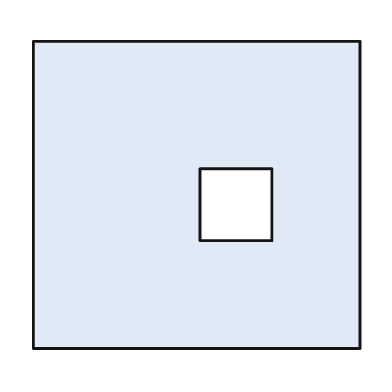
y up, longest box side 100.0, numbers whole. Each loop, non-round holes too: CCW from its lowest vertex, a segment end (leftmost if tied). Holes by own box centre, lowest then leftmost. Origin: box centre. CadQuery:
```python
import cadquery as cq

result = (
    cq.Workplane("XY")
    .moveTo(-50.0, -47.0)
    .lineTo(50.0, -47.0)
    .lineTo(50.0, 47.0)
    .lineTo(-50.0, 47.0)
    .close()
    .moveTo(1.0, -14.0)
    .lineTo(23.0, -14.0)
    .lineTo(23.0, 8.0)
    .lineTo(1.0, 8.0)
    .close()
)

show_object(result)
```